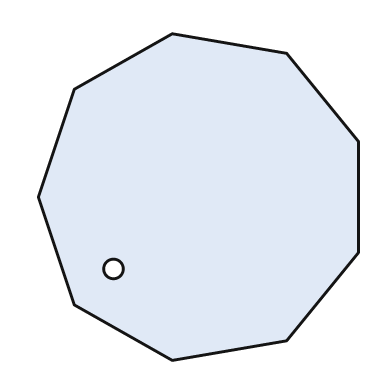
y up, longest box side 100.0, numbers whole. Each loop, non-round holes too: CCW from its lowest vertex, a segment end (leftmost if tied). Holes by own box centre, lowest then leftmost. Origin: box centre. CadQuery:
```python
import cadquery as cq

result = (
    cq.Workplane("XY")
    .moveTo(-8.0, -50.0)
    .lineTo(27.0, -44.0)
    .lineTo(49.0, -17.0)
    .lineTo(49.0, 17.0)
    .lineTo(27.0, 44.0)
    .lineTo(-8.0, 50.0)
    .lineTo(-38.0, 33.0)
    .lineTo(-49.0, 0.0)
    .lineTo(-38.0, -33.0)
    .close()
    .moveTo(-26.0, -22.0)
    .circle(3.0)
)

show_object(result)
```